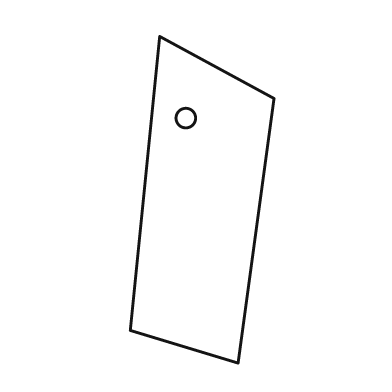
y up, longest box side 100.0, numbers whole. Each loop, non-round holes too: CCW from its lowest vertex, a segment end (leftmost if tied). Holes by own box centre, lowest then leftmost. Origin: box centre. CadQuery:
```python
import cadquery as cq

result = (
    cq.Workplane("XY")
    .moveTo(11.0, -50.0)
    .lineTo(22.0, 31.0)
    .lineTo(-13.0, 50.0)
    .lineTo(-22.0, -40.0)
    .close()
    .moveTo(-5.0, 25.0)
    .circle(3.0)
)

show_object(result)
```